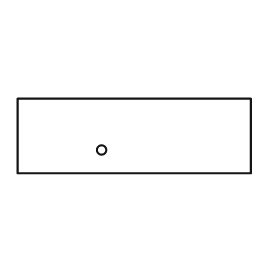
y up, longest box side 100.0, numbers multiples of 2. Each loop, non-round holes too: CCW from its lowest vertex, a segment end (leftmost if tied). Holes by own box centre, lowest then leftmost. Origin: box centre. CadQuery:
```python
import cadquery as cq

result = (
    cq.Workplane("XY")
    .moveTo(-50.0, -16.0)
    .lineTo(50.0, -16.0)
    .lineTo(50.0, 16.0)
    .lineTo(-50.0, 16.0)
    .close()
    .moveTo(-14.0, -6.0)
    .circle(2.0)
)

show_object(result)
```